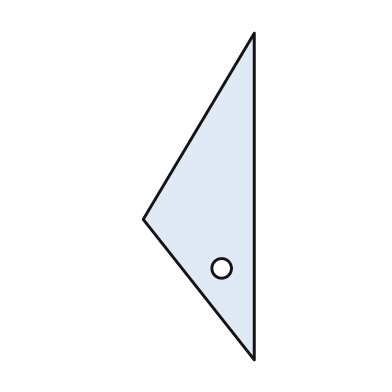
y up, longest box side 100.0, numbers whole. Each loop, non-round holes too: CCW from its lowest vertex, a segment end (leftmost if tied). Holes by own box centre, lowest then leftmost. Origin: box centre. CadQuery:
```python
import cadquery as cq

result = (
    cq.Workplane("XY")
    .moveTo(17.0, -50.0)
    .lineTo(17.0, 50.0)
    .lineTo(-17.0, -7.0)
    .close()
    .moveTo(7.0, -22.0)
    .circle(3.0)
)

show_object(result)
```